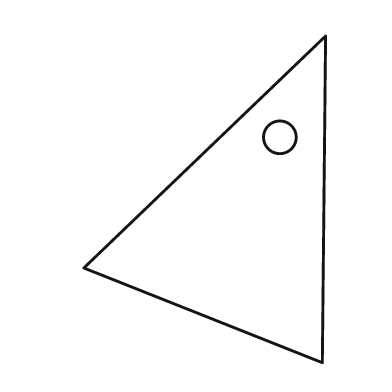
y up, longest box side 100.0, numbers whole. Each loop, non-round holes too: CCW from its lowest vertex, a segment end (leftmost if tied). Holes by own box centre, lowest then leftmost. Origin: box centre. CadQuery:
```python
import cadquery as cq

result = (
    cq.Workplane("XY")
    .moveTo(36.0, -50.0)
    .lineTo(37.0, 50.0)
    .lineTo(-37.0, -21.0)
    .close()
    .moveTo(23.0, 19.0)
    .circle(5.0)
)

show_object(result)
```